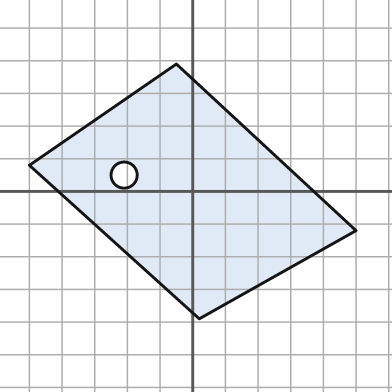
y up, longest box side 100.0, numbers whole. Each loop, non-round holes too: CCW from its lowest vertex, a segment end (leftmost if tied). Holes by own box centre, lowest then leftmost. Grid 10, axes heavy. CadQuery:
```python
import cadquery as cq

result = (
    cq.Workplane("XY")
    .moveTo(2.0, -39.0)
    .lineTo(50.0, -12.0)
    .lineTo(-5.0, 39.0)
    .lineTo(-50.0, 8.0)
    .close()
    .moveTo(-21.0, 5.0)
    .circle(4.0)
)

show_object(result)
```